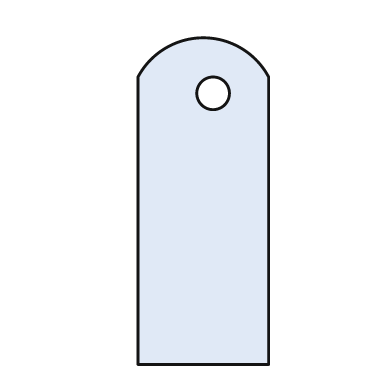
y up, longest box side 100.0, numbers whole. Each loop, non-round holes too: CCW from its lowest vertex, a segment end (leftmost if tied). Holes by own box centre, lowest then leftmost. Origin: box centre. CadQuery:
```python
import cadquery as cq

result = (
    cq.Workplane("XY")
    .moveTo(-20.0, -50.0)
    .lineTo(20.0, -50.0)
    .lineTo(20.0, 38.0)
    .threePointArc((0.0, 50.0), (-20.0, 38.0))
    .close()
    .moveTo(3.0, 33.0)
    .circle(5.0)
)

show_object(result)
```